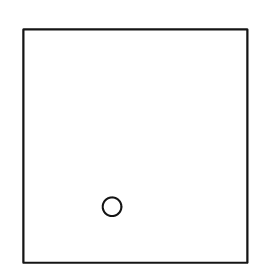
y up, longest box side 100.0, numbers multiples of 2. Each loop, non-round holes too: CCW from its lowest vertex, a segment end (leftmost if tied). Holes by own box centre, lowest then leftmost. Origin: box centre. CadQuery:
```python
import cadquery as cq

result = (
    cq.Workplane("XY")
    .moveTo(-48.0, -50.0)
    .lineTo(48.0, -50.0)
    .lineTo(48.0, 50.0)
    .lineTo(-48.0, 50.0)
    .close()
    .moveTo(-10.0, -26.0)
    .circle(4.0)
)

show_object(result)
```